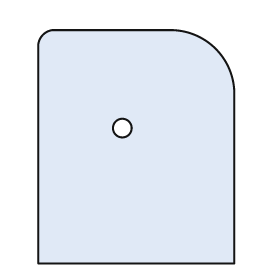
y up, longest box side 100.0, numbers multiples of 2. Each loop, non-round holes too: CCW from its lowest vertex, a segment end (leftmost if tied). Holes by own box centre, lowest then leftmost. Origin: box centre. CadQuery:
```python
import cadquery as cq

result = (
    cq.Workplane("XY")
    .moveTo(-42.0, -50.0)
    .lineTo(42.0, -50.0)
    .lineTo(42.0, 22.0)
    .threePointArc((34.0, 42.0), (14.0, 50.0))
    .lineTo(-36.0, 50.0)
    .threePointArc((-40.0, 48.0), (-42.0, 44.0))
    .close()
    .moveTo(-6.0, 8.0)
    .circle(4.0)
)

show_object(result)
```